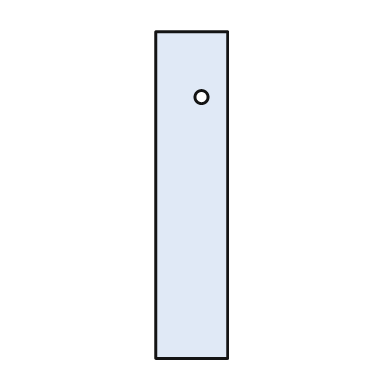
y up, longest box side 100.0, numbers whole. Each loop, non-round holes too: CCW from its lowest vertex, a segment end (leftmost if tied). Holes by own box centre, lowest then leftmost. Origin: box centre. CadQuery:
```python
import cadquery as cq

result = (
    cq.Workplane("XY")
    .moveTo(-11.0, -50.0)
    .lineTo(11.0, -50.0)
    .lineTo(11.0, 50.0)
    .lineTo(-11.0, 50.0)
    .close()
    .moveTo(3.0, 30.0)
    .circle(2.0)
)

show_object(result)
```